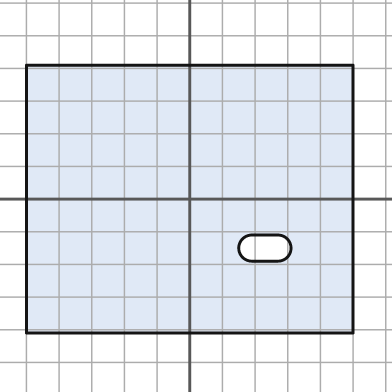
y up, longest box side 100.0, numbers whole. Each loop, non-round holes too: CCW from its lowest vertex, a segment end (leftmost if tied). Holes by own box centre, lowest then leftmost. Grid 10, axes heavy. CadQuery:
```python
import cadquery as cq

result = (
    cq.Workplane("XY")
    .moveTo(-50.0, -41.0)
    .lineTo(50.0, -41.0)
    .lineTo(50.0, 41.0)
    .lineTo(-50.0, 41.0)
    .close()
    .moveTo(19.0, -19.0)
    .lineTo(27.0, -19.0)
    .threePointArc((31.0, -15.0), (27.0, -11.0))
    .lineTo(19.0, -11.0)
    .threePointArc((15.0, -15.0), (19.0, -19.0))
    .close()
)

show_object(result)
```